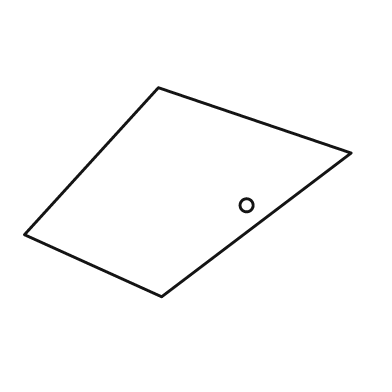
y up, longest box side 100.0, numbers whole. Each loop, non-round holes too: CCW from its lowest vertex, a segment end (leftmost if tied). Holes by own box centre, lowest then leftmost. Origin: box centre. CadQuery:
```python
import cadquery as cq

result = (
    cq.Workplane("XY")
    .moveTo(-8.0, -32.0)
    .lineTo(50.0, 12.0)
    .lineTo(-9.0, 32.0)
    .lineTo(-50.0, -13.0)
    .close()
    .moveTo(18.0, -4.0)
    .circle(2.0)
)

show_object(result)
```